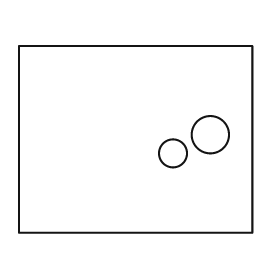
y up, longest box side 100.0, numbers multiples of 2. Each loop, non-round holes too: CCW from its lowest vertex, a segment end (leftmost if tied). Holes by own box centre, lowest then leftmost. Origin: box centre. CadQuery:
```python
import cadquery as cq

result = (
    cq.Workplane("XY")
    .moveTo(-50.0, -40.0)
    .lineTo(50.0, -40.0)
    .lineTo(50.0, 40.0)
    .lineTo(-50.0, 40.0)
    .close()
    .moveTo(16.0, -6.0)
    .circle(6.0)
    .moveTo(32.0, 2.0)
    .circle(8.0)
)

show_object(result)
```